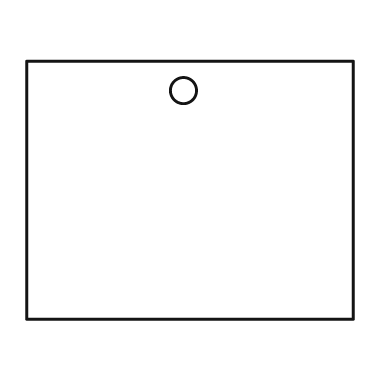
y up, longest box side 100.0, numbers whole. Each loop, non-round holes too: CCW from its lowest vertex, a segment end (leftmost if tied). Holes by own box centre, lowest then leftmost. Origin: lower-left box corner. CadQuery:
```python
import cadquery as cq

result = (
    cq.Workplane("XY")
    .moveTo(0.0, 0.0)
    .lineTo(100.0, 0.0)
    .lineTo(100.0, 79.0)
    .lineTo(0.0, 79.0)
    .close()
    .moveTo(48.0, 70.0)
    .circle(4.0)
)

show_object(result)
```